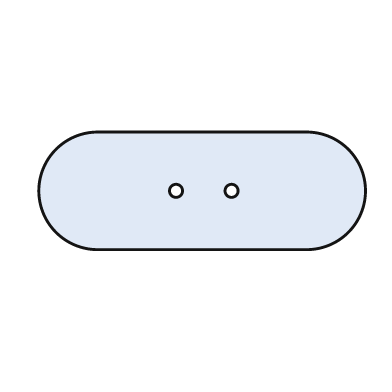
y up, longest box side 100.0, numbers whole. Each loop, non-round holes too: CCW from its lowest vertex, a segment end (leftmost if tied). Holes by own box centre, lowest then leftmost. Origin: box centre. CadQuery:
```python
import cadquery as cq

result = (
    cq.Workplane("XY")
    .moveTo(-32.0, -18.0)
    .lineTo(32.0, -18.0)
    .threePointArc((50.0, 0.0), (32.0, 18.0))
    .lineTo(-32.0, 18.0)
    .threePointArc((-50.0, 0.0), (-32.0, -18.0))
    .close()
    .moveTo(-8.0, 0.0)
    .circle(2.0)
    .moveTo(9.0, 0.0)
    .circle(2.0)
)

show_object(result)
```